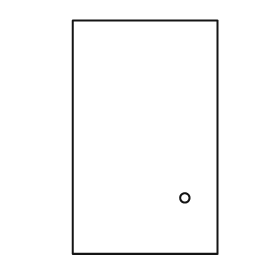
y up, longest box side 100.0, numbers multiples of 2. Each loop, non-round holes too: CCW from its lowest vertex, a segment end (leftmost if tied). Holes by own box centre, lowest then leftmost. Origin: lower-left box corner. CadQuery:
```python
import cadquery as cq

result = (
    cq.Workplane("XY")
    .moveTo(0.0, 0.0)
    .lineTo(62.0, 0.0)
    .lineTo(62.0, 100.0)
    .lineTo(0.0, 100.0)
    .close()
    .moveTo(48.0, 24.0)
    .circle(2.0)
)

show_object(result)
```